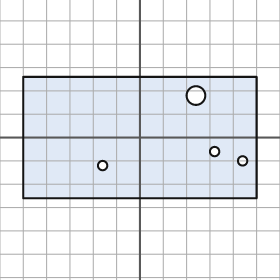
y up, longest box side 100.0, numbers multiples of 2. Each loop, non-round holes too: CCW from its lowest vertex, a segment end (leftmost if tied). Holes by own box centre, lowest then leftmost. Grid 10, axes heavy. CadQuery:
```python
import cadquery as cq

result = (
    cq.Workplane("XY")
    .moveTo(-50.0, -26.0)
    .lineTo(50.0, -26.0)
    .lineTo(50.0, 26.0)
    .lineTo(-50.0, 26.0)
    .close()
    .moveTo(-16.0, -12.0)
    .circle(2.0)
    .moveTo(44.0, -10.0)
    .circle(2.0)
    .moveTo(32.0, -6.0)
    .circle(2.0)
    .moveTo(24.0, 18.0)
    .circle(4.0)
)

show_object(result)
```